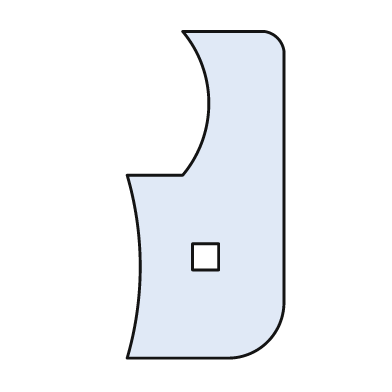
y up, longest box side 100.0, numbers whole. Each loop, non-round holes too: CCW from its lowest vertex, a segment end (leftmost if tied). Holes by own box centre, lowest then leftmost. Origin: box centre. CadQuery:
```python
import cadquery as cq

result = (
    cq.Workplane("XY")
    .moveTo(-24.0, -50.0)
    .lineTo(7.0, -50.0)
    .threePointArc((19.0, -45.0), (24.0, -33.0))
    .lineTo(24.0, 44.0)
    .threePointArc((22.0, 48.0), (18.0, 50.0))
    .lineTo(-7.0, 50.0)
    .threePointArc((1.0, 28.0), (-7.0, 6.0))
    .lineTo(-24.0, 6.0)
    .threePointArc((-20.0, -22.0), (-24.0, -50.0))
    .close()
    .moveTo(-4.0, -23.0)
    .lineTo(4.0, -23.0)
    .lineTo(4.0, -15.0)
    .lineTo(-4.0, -15.0)
    .close()
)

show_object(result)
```